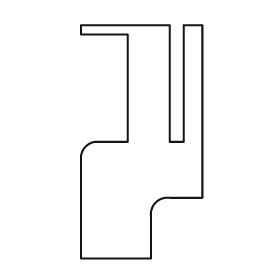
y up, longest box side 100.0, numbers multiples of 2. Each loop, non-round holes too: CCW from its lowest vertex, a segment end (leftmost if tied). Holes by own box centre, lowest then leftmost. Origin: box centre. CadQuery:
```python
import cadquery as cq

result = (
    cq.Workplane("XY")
    .moveTo(-26.0, -50.0)
    .lineTo(4.0, -50.0)
    .lineTo(4.0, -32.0)
    .threePointArc((6.0, -26.0), (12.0, -24.0))
    .lineTo(26.0, -24.0)
    .lineTo(26.0, 50.0)
    .lineTo(18.0, 50.0)
    .lineTo(18.0, 0.0)
    .lineTo(12.0, 0.0)
    .lineTo(12.0, 50.0)
    .lineTo(-26.0, 50.0)
    .lineTo(-26.0, 46.0)
    .lineTo(-6.0, 46.0)
    .lineTo(-6.0, 0.0)
    .lineTo(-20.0, 0.0)
    .threePointArc((-24.0, -2.0), (-26.0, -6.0))
    .close()
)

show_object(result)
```